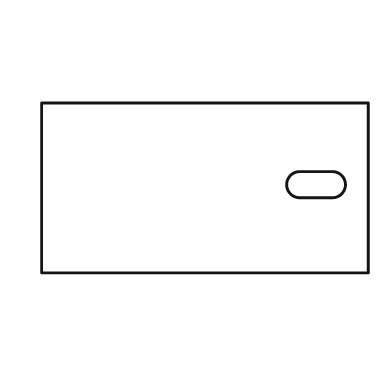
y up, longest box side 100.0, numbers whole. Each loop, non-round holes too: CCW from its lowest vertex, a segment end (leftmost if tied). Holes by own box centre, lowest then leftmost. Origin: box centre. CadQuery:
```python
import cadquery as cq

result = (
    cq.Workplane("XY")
    .moveTo(-50.0, -26.0)
    .lineTo(50.0, -26.0)
    .lineTo(50.0, 26.0)
    .lineTo(-50.0, 26.0)
    .close()
    .moveTo(29.0, -3.0)
    .lineTo(39.0, -3.0)
    .threePointArc((43.0, 1.0), (39.0, 5.0))
    .lineTo(29.0, 5.0)
    .threePointArc((25.0, 1.0), (29.0, -3.0))
    .close()
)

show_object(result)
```